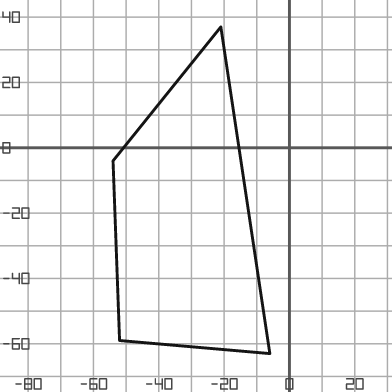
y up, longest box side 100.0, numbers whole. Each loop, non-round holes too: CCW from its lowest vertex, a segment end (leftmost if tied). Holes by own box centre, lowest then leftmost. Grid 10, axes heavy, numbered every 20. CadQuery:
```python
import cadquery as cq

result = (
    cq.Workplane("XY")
    .moveTo(-6.0, -63.0)
    .lineTo(-21.0, 37.0)
    .lineTo(-54.0, -4.0)
    .lineTo(-52.0, -59.0)
    .close()
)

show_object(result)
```